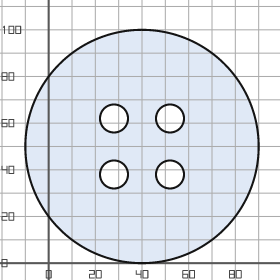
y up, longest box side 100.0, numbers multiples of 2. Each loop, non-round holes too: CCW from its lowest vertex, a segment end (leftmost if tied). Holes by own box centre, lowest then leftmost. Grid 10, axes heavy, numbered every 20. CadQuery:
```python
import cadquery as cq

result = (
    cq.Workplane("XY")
    .moveTo(40.0, 50.0)
    .circle(50.0)
    .moveTo(28.0, 38.0)
    .circle(6.0)
    .moveTo(52.0, 38.0)
    .circle(6.0)
    .moveTo(28.0, 62.0)
    .circle(6.0)
    .moveTo(52.0, 62.0)
    .circle(6.0)
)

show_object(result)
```